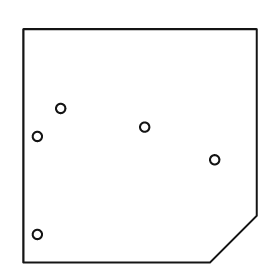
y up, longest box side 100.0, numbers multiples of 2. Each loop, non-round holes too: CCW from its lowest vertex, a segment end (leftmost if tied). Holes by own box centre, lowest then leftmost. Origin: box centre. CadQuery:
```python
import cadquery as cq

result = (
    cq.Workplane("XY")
    .moveTo(-50.0, -50.0)
    .lineTo(30.0, -50.0)
    .lineTo(50.0, -30.0)
    .lineTo(50.0, 50.0)
    .lineTo(-50.0, 50.0)
    .close()
    .moveTo(-44.0, -38.0)
    .circle(2.0)
    .moveTo(32.0, -6.0)
    .circle(2.0)
    .moveTo(-44.0, 4.0)
    .circle(2.0)
    .moveTo(2.0, 8.0)
    .circle(2.0)
    .moveTo(-34.0, 16.0)
    .circle(2.0)
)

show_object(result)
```